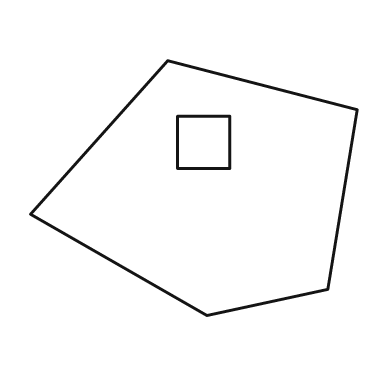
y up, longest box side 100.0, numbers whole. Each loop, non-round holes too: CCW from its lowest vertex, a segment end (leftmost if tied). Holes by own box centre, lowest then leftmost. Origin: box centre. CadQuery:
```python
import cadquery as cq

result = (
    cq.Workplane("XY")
    .moveTo(4.0, -39.0)
    .lineTo(41.0, -31.0)
    .lineTo(50.0, 24.0)
    .lineTo(-8.0, 39.0)
    .lineTo(-50.0, -8.0)
    .close()
    .moveTo(-5.0, 6.0)
    .lineTo(11.0, 6.0)
    .lineTo(11.0, 22.0)
    .lineTo(-5.0, 22.0)
    .close()
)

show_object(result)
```